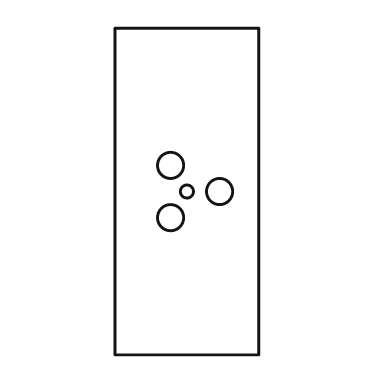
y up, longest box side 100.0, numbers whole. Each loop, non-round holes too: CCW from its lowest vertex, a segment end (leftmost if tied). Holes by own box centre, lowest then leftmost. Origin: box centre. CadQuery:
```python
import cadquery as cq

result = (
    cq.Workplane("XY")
    .moveTo(-22.0, -50.0)
    .lineTo(22.0, -50.0)
    .lineTo(22.0, 50.0)
    .lineTo(-22.0, 50.0)
    .close()
    .moveTo(-5.0, -8.0)
    .circle(4.0)
    .moveTo(0.0, 0.0)
    .circle(2.0)
    .moveTo(10.0, 0.0)
    .circle(4.0)
    .moveTo(-5.0, 8.0)
    .circle(4.0)
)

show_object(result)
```